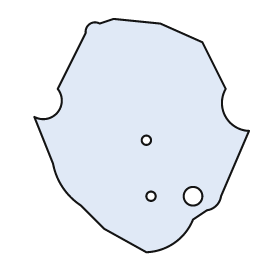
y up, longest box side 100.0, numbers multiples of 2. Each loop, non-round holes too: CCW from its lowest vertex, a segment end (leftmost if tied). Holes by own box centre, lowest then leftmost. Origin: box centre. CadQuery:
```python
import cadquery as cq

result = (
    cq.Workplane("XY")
    .moveTo(2.0, -50.0)
    .threePointArc((14.0, -46.0), (22.0, -36.0))
    .lineTo(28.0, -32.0)
    .threePointArc((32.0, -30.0), (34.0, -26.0))
    .lineTo(46.0, 2.0)
    .threePointArc((36.0, 8.0), (36.0, 20.0))
    .lineTo(26.0, 40.0)
    .lineTo(8.0, 48.0)
    .lineTo(-12.0, 50.0)
    .lineTo(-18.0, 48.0)
    .threePointArc((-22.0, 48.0), (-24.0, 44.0))
    .lineTo(-36.0, 20.0)
    .threePointArc((-36.0, 10.0), (-46.0, 8.0))
    .lineTo(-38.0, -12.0)
    .threePointArc((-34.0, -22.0), (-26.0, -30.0))
    .lineTo(-16.0, -40.0)
    .close()
    .moveTo(4.0, -26.0)
    .circle(2.0)
    .moveTo(22.0, -26.0)
    .circle(4.0)
    .moveTo(2.0, -2.0)
    .circle(2.0)
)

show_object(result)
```